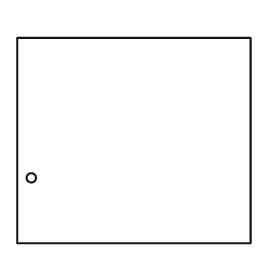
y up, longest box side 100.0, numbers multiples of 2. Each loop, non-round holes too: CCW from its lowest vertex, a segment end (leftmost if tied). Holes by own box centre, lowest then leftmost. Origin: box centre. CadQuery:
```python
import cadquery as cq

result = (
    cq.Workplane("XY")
    .moveTo(-50.0, -44.0)
    .lineTo(50.0, -44.0)
    .lineTo(50.0, 44.0)
    .lineTo(-50.0, 44.0)
    .close()
    .moveTo(-44.0, -16.0)
    .circle(2.0)
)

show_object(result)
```